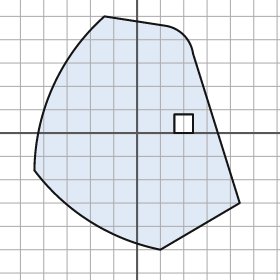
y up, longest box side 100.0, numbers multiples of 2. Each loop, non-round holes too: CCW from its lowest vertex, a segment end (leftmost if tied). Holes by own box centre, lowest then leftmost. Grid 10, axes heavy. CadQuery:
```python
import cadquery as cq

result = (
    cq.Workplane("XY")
    .moveTo(10.0, -50.0)
    .lineTo(44.0, -30.0)
    .lineTo(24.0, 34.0)
    .threePointArc((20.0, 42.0), (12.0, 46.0))
    .lineTo(-14.0, 50.0)
    .threePointArc((-36.0, 20.0), (-44.0, -16.0))
    .threePointArc((-20.0, -38.0), (10.0, -50.0))
    .close()
    .moveTo(16.0, 0.0)
    .lineTo(24.0, 0.0)
    .lineTo(24.0, 8.0)
    .lineTo(16.0, 8.0)
    .close()
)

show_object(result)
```